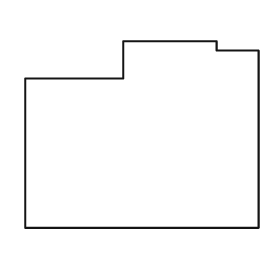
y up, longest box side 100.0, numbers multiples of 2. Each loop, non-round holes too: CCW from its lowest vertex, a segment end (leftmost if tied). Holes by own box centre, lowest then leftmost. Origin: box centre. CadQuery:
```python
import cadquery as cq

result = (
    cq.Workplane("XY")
    .moveTo(-50.0, -40.0)
    .lineTo(50.0, -40.0)
    .lineTo(50.0, 36.0)
    .lineTo(32.0, 36.0)
    .lineTo(32.0, 40.0)
    .lineTo(-8.0, 40.0)
    .lineTo(-8.0, 24.0)
    .lineTo(-50.0, 24.0)
    .close()
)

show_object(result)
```